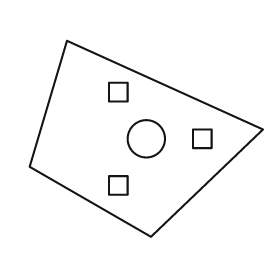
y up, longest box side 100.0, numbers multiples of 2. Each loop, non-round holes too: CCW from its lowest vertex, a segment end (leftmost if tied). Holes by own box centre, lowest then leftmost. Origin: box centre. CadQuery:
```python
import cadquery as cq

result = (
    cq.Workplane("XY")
    .moveTo(2.0, -42.0)
    .lineTo(50.0, 4.0)
    .lineTo(-34.0, 42.0)
    .lineTo(-50.0, -12.0)
    .close()
    .moveTo(-16.0, -24.0)
    .lineTo(-8.0, -24.0)
    .lineTo(-8.0, -16.0)
    .lineTo(-16.0, -16.0)
    .close()
    .moveTo(0.0, 0.0)
    .circle(8.0)
    .moveTo(20.0, -4.0)
    .lineTo(28.0, -4.0)
    .lineTo(28.0, 4.0)
    .lineTo(20.0, 4.0)
    .close()
    .moveTo(-16.0, 16.0)
    .lineTo(-8.0, 16.0)
    .lineTo(-8.0, 24.0)
    .lineTo(-16.0, 24.0)
    .close()
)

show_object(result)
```